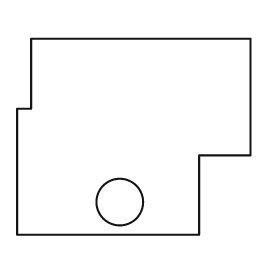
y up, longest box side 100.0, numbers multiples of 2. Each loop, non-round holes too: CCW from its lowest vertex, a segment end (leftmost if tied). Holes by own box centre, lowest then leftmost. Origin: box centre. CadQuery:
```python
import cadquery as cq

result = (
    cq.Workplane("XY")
    .moveTo(-50.0, -42.0)
    .lineTo(28.0, -42.0)
    .lineTo(28.0, -8.0)
    .lineTo(50.0, -8.0)
    .lineTo(50.0, 42.0)
    .lineTo(-44.0, 42.0)
    .lineTo(-44.0, 12.0)
    .lineTo(-50.0, 12.0)
    .close()
    .moveTo(-6.0, -28.0)
    .circle(10.0)
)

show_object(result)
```